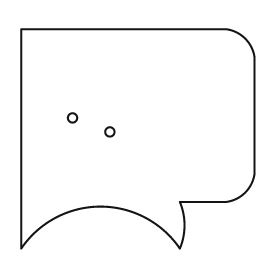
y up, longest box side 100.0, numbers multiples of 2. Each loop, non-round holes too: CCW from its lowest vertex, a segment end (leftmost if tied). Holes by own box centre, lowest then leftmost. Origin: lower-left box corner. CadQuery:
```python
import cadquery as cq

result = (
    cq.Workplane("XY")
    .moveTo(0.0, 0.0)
    .threePointArc((34.0, 18.0), (68.0, 0.0))
    .threePointArc((70.0, 10.0), (68.0, 20.0))
    .lineTo(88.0, 20.0)
    .threePointArc((96.0, 24.0), (100.0, 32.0))
    .lineTo(100.0, 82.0)
    .threePointArc((96.0, 90.0), (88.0, 94.0))
    .lineTo(0.0, 94.0)
    .close()
    .moveTo(38.0, 50.0)
    .circle(2.0)
    .moveTo(22.0, 56.0)
    .circle(2.0)
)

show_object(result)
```